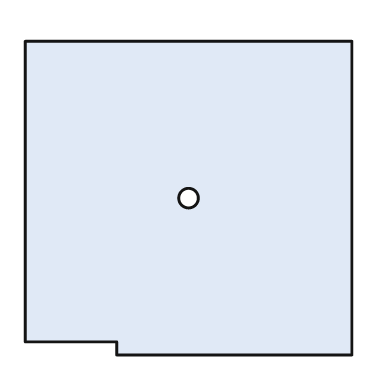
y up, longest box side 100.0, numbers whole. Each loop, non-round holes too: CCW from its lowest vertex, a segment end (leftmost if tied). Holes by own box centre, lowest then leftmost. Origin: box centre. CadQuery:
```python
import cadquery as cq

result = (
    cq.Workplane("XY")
    .moveTo(-22.0, -48.0)
    .lineTo(50.0, -48.0)
    .lineTo(50.0, 48.0)
    .lineTo(-50.0, 48.0)
    .lineTo(-50.0, -44.0)
    .lineTo(-22.0, -44.0)
    .close()
    .moveTo(0.0, 0.0)
    .circle(3.0)
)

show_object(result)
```